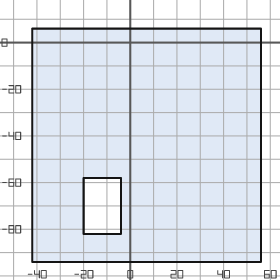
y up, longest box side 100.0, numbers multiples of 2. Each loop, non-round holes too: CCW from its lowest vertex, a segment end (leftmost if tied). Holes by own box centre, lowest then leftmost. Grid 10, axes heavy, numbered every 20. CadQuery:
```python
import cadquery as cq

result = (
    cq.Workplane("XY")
    .moveTo(-42.0, -94.0)
    .lineTo(56.0, -94.0)
    .lineTo(56.0, 6.0)
    .lineTo(-42.0, 6.0)
    .close()
    .moveTo(-20.0, -82.0)
    .lineTo(-4.0, -82.0)
    .lineTo(-4.0, -58.0)
    .lineTo(-20.0, -58.0)
    .close()
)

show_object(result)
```